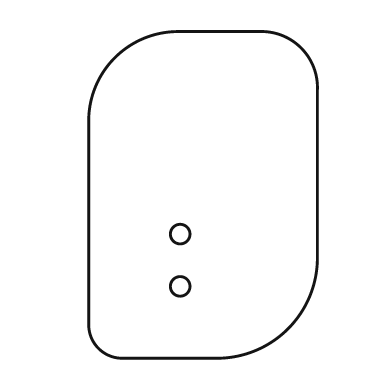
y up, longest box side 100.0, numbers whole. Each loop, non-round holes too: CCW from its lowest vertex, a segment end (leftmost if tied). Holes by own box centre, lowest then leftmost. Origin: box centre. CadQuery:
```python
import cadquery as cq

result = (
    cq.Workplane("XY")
    .moveTo(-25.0, -50.0)
    .lineTo(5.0, -50.0)
    .threePointArc((26.0, -41.0), (35.0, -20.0))
    .lineTo(35.0, 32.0)
    .threePointArc((30.0, 45.0), (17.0, 50.0))
    .lineTo(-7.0, 50.0)
    .threePointArc((-27.0, 42.0), (-35.0, 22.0))
    .lineTo(-35.0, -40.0)
    .threePointArc((-32.0, -47.0), (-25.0, -50.0))
    .close()
    .moveTo(-7.0, -28.0)
    .circle(3.0)
    .moveTo(-7.0, -12.0)
    .circle(3.0)
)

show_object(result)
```